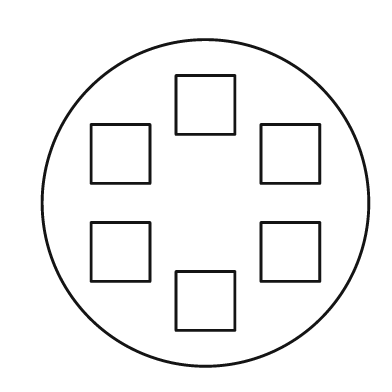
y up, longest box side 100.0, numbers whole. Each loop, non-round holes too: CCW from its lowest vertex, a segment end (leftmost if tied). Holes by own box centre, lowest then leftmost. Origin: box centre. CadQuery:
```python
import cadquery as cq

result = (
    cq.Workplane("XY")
    .moveTo(0.0, 0.0)
    .circle(50.0)
    .moveTo(-9.0, -39.0)
    .lineTo(9.0, -39.0)
    .lineTo(9.0, -21.0)
    .lineTo(-9.0, -21.0)
    .close()
    .moveTo(-35.0, -24.0)
    .lineTo(-17.0, -24.0)
    .lineTo(-17.0, -6.0)
    .lineTo(-35.0, -6.0)
    .close()
    .moveTo(17.0, -24.0)
    .lineTo(35.0, -24.0)
    .lineTo(35.0, -6.0)
    .lineTo(17.0, -6.0)
    .close()
    .moveTo(-35.0, 6.0)
    .lineTo(-17.0, 6.0)
    .lineTo(-17.0, 24.0)
    .lineTo(-35.0, 24.0)
    .close()
    .moveTo(17.0, 6.0)
    .lineTo(35.0, 6.0)
    .lineTo(35.0, 24.0)
    .lineTo(17.0, 24.0)
    .close()
    .moveTo(-9.0, 21.0)
    .lineTo(9.0, 21.0)
    .lineTo(9.0, 39.0)
    .lineTo(-9.0, 39.0)
    .close()
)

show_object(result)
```